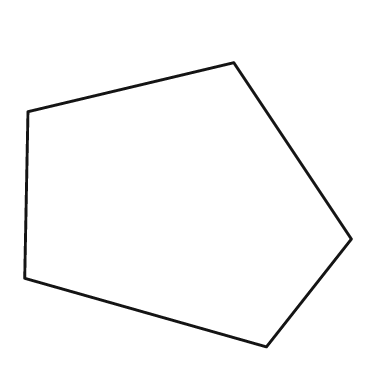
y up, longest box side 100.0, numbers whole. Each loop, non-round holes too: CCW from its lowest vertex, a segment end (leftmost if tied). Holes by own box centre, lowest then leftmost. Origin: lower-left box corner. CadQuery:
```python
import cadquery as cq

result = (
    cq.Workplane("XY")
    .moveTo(74.0, 0.0)
    .lineTo(100.0, 33.0)
    .lineTo(64.0, 87.0)
    .lineTo(1.0, 72.0)
    .lineTo(0.0, 21.0)
    .close()
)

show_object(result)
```